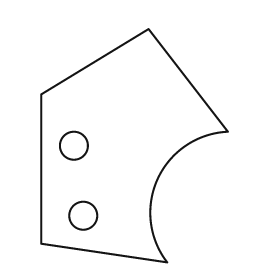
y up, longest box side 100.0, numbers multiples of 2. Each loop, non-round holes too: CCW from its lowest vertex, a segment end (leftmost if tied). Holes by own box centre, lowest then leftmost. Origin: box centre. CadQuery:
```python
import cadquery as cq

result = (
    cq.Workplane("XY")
    .moveTo(14.0, -50.0)
    .threePointArc((10.0, -14.0), (40.0, 6.0))
    .lineTo(6.0, 50.0)
    .lineTo(-40.0, 22.0)
    .lineTo(-40.0, -42.0)
    .close()
    .moveTo(-22.0, -30.0)
    .circle(6.0)
    .moveTo(-26.0, 0.0)
    .circle(6.0)
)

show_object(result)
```